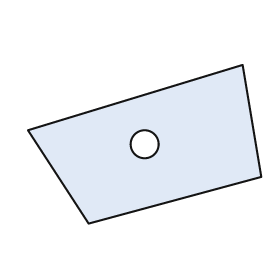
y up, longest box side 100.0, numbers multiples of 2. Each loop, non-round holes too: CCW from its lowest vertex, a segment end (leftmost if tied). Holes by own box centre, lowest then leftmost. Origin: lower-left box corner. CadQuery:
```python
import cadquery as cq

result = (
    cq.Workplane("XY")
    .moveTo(26.0, 0.0)
    .lineTo(100.0, 20.0)
    .lineTo(92.0, 68.0)
    .lineTo(0.0, 40.0)
    .close()
    .moveTo(50.0, 34.0)
    .circle(6.0)
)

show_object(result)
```